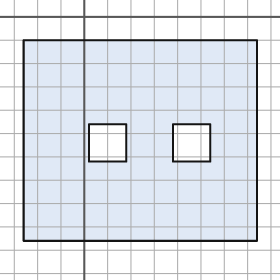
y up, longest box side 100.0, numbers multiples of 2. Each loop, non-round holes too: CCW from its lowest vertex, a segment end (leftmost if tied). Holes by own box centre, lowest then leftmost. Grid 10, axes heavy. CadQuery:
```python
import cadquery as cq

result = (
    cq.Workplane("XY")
    .moveTo(-26.0, -96.0)
    .lineTo(74.0, -96.0)
    .lineTo(74.0, -10.0)
    .lineTo(-26.0, -10.0)
    .close()
    .moveTo(2.0, -62.0)
    .lineTo(18.0, -62.0)
    .lineTo(18.0, -46.0)
    .lineTo(2.0, -46.0)
    .close()
    .moveTo(38.0, -62.0)
    .lineTo(54.0, -62.0)
    .lineTo(54.0, -46.0)
    .lineTo(38.0, -46.0)
    .close()
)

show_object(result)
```